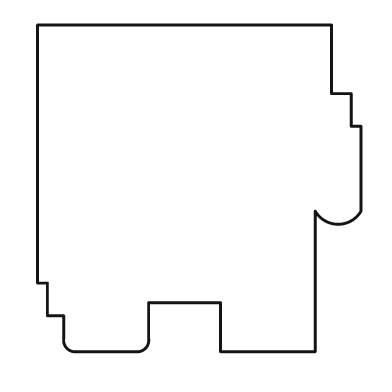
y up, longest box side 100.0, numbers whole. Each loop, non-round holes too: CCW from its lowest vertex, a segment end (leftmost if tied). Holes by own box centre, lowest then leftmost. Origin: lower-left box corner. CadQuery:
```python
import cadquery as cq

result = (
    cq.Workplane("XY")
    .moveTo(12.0, 0.0)
    .lineTo(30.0, 0.0)
    .threePointArc((33.0, 1.0), (34.0, 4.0))
    .lineTo(34.0, 15.0)
    .lineTo(56.0, 15.0)
    .lineTo(56.0, 0.0)
    .lineTo(85.0, 0.0)
    .lineTo(85.0, 43.0)
    .threePointArc((92.0, 39.0), (99.0, 43.0))
    .lineTo(99.0, 69.0)
    .lineTo(96.0, 69.0)
    .lineTo(96.0, 79.0)
    .lineTo(90.0, 79.0)
    .lineTo(90.0, 100.0)
    .lineTo(0.0, 100.0)
    .lineTo(0.0, 21.0)
    .lineTo(3.0, 21.0)
    .lineTo(3.0, 11.0)
    .lineTo(8.0, 11.0)
    .lineTo(8.0, 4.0)
    .threePointArc((9.0, 1.0), (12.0, 0.0))
    .close()
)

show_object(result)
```